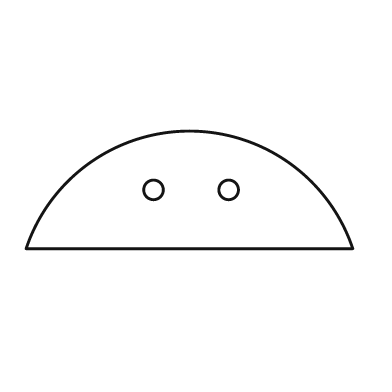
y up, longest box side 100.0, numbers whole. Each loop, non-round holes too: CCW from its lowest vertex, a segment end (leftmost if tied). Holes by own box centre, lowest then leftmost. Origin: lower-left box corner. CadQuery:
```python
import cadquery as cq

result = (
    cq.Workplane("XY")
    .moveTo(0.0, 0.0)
    .lineTo(100.0, 0.0)
    .threePointArc((50.0, 36.0), (0.0, 0.0))
    .close()
    .moveTo(39.0, 18.0)
    .circle(3.0)
    .moveTo(62.0, 18.0)
    .circle(3.0)
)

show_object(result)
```